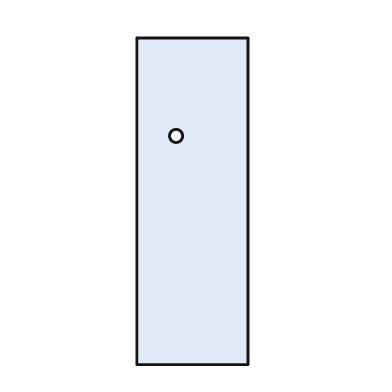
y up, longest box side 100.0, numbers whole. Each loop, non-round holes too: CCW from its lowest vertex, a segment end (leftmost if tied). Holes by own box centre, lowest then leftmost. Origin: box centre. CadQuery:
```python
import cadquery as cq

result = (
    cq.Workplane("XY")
    .moveTo(-17.0, -50.0)
    .lineTo(17.0, -50.0)
    .lineTo(17.0, 50.0)
    .lineTo(-17.0, 50.0)
    .close()
    .moveTo(-5.0, 20.0)
    .circle(2.0)
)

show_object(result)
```